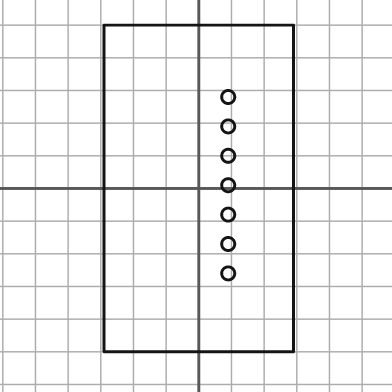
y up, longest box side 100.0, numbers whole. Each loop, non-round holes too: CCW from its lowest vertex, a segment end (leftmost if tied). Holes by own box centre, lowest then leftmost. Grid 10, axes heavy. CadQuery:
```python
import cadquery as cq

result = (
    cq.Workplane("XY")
    .moveTo(-29.0, -50.0)
    .lineTo(29.0, -50.0)
    .lineTo(29.0, 50.0)
    .lineTo(-29.0, 50.0)
    .close()
    .moveTo(9.0, -26.0)
    .circle(2.0)
    .moveTo(9.0, -17.0)
    .circle(2.0)
    .moveTo(9.0, -8.0)
    .circle(2.0)
    .moveTo(9.0, 1.0)
    .circle(2.0)
    .moveTo(9.0, 10.0)
    .circle(2.0)
    .moveTo(9.0, 19.0)
    .circle(2.0)
    .moveTo(9.0, 28.0)
    .circle(2.0)
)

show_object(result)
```